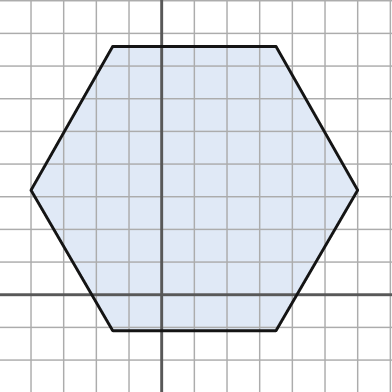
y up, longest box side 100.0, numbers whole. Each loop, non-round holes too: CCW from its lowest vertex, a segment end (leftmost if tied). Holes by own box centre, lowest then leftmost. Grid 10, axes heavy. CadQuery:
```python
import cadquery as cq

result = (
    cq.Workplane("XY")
    .moveTo(-15.0, -11.0)
    .lineTo(35.0, -11.0)
    .lineTo(60.0, 32.0)
    .lineTo(35.0, 76.0)
    .lineTo(-15.0, 76.0)
    .lineTo(-40.0, 32.0)
    .close()
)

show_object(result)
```